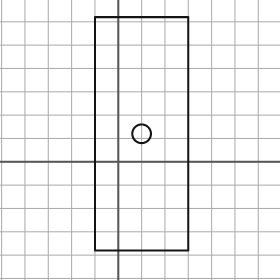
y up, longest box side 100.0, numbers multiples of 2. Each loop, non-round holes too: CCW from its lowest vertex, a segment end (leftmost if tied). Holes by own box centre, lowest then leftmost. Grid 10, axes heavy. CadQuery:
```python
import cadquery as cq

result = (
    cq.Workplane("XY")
    .moveTo(-10.0, -38.0)
    .lineTo(30.0, -38.0)
    .lineTo(30.0, 62.0)
    .lineTo(-10.0, 62.0)
    .close()
    .moveTo(10.0, 12.0)
    .circle(4.0)
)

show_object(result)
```